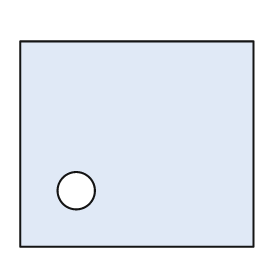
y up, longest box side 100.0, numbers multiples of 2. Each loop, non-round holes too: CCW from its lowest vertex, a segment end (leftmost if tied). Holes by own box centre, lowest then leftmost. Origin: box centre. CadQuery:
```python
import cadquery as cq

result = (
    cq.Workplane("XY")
    .moveTo(-50.0, -44.0)
    .lineTo(50.0, -44.0)
    .lineTo(50.0, 44.0)
    .lineTo(-50.0, 44.0)
    .close()
    .moveTo(-26.0, -20.0)
    .circle(8.0)
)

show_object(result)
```